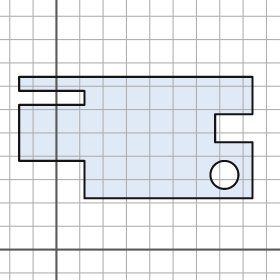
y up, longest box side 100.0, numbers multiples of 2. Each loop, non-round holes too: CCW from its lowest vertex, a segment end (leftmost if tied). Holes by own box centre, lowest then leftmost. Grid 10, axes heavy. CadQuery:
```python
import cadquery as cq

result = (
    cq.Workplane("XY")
    .moveTo(12.0, 22.0)
    .lineTo(84.0, 22.0)
    .lineTo(84.0, 46.0)
    .lineTo(68.0, 46.0)
    .lineTo(68.0, 58.0)
    .lineTo(84.0, 58.0)
    .lineTo(84.0, 74.0)
    .lineTo(-16.0, 74.0)
    .lineTo(-16.0, 68.0)
    .lineTo(12.0, 68.0)
    .lineTo(12.0, 62.0)
    .lineTo(-16.0, 62.0)
    .lineTo(-16.0, 38.0)
    .lineTo(12.0, 38.0)
    .close()
    .moveTo(72.0, 32.0)
    .circle(6.0)
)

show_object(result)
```